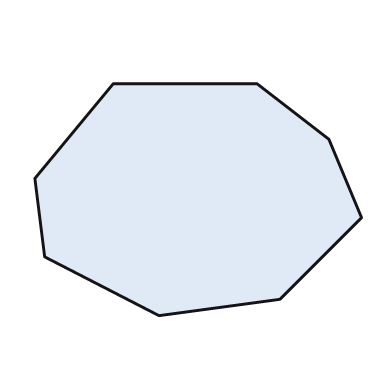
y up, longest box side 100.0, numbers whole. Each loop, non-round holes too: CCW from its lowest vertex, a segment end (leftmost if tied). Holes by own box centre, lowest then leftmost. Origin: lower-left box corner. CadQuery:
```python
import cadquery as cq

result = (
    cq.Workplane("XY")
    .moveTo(38.0, 0.0)
    .lineTo(75.0, 5.0)
    .lineTo(100.0, 30.0)
    .lineTo(90.0, 54.0)
    .lineTo(68.0, 71.0)
    .lineTo(24.0, 71.0)
    .lineTo(0.0, 42.0)
    .lineTo(3.0, 18.0)
    .close()
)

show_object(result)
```